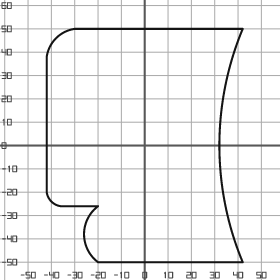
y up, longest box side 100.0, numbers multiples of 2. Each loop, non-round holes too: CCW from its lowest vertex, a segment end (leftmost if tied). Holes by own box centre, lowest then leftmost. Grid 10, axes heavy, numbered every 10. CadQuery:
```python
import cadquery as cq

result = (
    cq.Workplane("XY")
    .moveTo(-20.0, -50.0)
    .lineTo(42.0, -50.0)
    .threePointArc((32.0, 0.0), (42.0, 50.0))
    .lineTo(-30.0, 50.0)
    .threePointArc((-38.0, 46.0), (-42.0, 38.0))
    .lineTo(-42.0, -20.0)
    .threePointArc((-40.0, -24.0), (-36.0, -26.0))
    .lineTo(-20.0, -26.0)
    .threePointArc((-26.0, -38.0), (-20.0, -50.0))
    .close()
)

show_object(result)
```